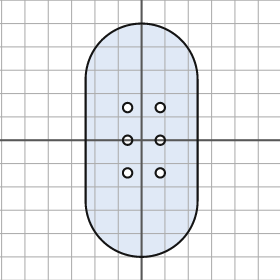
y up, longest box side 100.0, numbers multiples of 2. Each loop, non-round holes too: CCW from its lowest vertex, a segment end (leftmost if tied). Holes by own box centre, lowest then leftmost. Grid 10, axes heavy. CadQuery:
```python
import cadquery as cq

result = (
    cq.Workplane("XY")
    .moveTo(-24.0, -26.0)
    .threePointArc((0.0, -50.0), (24.0, -26.0))
    .lineTo(24.0, 26.0)
    .threePointArc((0.0, 50.0), (-24.0, 26.0))
    .close()
    .moveTo(-6.0, -14.0)
    .circle(2.0)
    .moveTo(8.0, -14.0)
    .circle(2.0)
    .moveTo(-6.0, 0.0)
    .circle(2.0)
    .moveTo(8.0, 0.0)
    .circle(2.0)
    .moveTo(-6.0, 14.0)
    .circle(2.0)
    .moveTo(8.0, 14.0)
    .circle(2.0)
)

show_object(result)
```